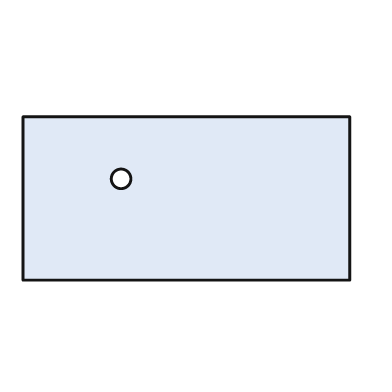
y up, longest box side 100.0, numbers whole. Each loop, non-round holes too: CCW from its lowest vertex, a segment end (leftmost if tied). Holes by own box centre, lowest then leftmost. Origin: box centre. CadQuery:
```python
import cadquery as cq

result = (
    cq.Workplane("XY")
    .moveTo(-50.0, -25.0)
    .lineTo(50.0, -25.0)
    .lineTo(50.0, 25.0)
    .lineTo(-50.0, 25.0)
    .close()
    .moveTo(-20.0, 6.0)
    .circle(3.0)
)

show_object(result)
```